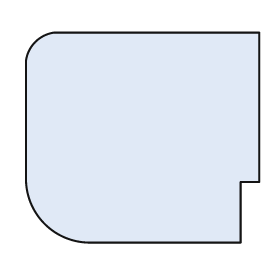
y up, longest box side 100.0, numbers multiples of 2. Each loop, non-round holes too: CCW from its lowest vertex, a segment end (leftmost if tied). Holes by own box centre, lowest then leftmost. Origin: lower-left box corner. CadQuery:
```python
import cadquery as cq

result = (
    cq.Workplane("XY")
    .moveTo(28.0, 0.0)
    .lineTo(92.0, 0.0)
    .lineTo(92.0, 26.0)
    .lineTo(100.0, 26.0)
    .lineTo(100.0, 90.0)
    .lineTo(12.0, 90.0)
    .threePointArc((4.0, 86.0), (0.0, 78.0))
    .lineTo(0.0, 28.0)
    .threePointArc((8.0, 8.0), (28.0, 0.0))
    .close()
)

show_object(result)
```